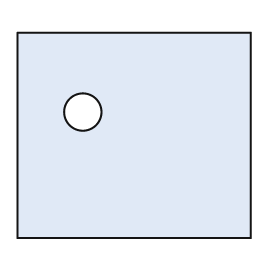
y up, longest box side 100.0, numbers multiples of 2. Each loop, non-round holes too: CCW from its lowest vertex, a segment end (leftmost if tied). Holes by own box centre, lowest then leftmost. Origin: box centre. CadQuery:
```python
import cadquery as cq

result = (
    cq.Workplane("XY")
    .moveTo(-50.0, -44.0)
    .lineTo(50.0, -44.0)
    .lineTo(50.0, 44.0)
    .lineTo(-50.0, 44.0)
    .close()
    .moveTo(-22.0, 10.0)
    .circle(8.0)
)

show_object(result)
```